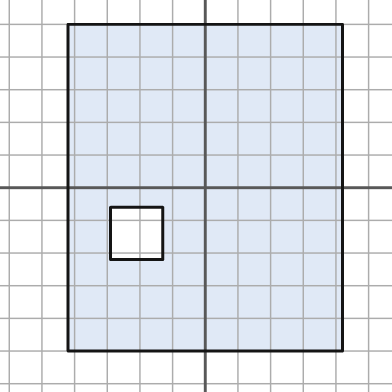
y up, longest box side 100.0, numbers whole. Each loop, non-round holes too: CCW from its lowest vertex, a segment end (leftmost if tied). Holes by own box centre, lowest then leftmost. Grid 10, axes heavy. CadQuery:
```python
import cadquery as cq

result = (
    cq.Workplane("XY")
    .moveTo(-42.0, -50.0)
    .lineTo(42.0, -50.0)
    .lineTo(42.0, 50.0)
    .lineTo(-42.0, 50.0)
    .close()
    .moveTo(-29.0, -22.0)
    .lineTo(-13.0, -22.0)
    .lineTo(-13.0, -6.0)
    .lineTo(-29.0, -6.0)
    .close()
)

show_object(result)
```